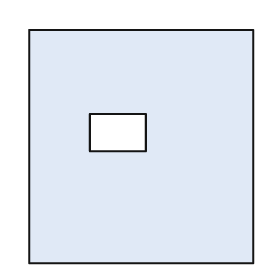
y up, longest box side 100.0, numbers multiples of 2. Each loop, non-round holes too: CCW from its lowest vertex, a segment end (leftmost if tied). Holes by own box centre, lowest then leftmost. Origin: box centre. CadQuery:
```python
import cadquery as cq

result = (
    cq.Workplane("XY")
    .moveTo(-48.0, -50.0)
    .lineTo(48.0, -50.0)
    .lineTo(48.0, 50.0)
    .lineTo(-48.0, 50.0)
    .close()
    .moveTo(-22.0, -2.0)
    .lineTo(2.0, -2.0)
    .lineTo(2.0, 14.0)
    .lineTo(-22.0, 14.0)
    .close()
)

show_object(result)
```